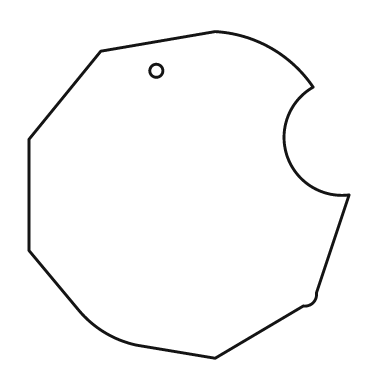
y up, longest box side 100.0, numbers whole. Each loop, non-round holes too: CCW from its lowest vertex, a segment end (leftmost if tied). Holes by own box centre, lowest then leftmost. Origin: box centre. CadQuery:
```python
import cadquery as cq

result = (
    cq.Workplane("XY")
    .moveTo(8.0, -50.0)
    .lineTo(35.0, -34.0)
    .threePointArc((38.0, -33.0), (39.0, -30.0))
    .lineTo(49.0, 0.0)
    .threePointArc((30.0, 12.0), (38.0, 33.0))
    .threePointArc((25.0, 45.0), (8.0, 50.0))
    .lineTo(-27.0, 44.0)
    .lineTo(-49.0, 17.0)
    .lineTo(-49.0, -17.0)
    .lineTo(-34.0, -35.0)
    .threePointArc((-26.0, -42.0), (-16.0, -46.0))
    .close()
    .moveTo(-10.0, 38.0)
    .circle(2.0)
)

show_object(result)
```